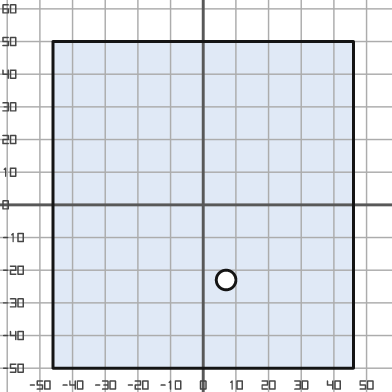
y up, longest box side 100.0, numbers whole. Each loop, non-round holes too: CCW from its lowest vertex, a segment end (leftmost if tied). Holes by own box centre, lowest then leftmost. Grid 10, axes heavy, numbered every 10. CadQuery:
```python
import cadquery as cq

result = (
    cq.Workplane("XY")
    .moveTo(-46.0, -50.0)
    .lineTo(46.0, -50.0)
    .lineTo(46.0, 50.0)
    .lineTo(-46.0, 50.0)
    .close()
    .moveTo(7.0, -23.0)
    .circle(3.0)
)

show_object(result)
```